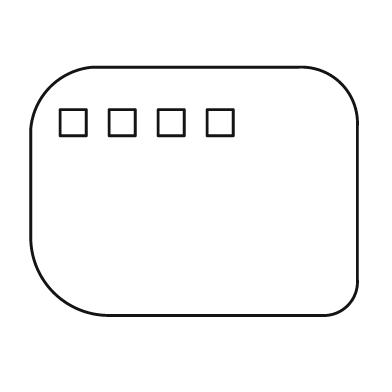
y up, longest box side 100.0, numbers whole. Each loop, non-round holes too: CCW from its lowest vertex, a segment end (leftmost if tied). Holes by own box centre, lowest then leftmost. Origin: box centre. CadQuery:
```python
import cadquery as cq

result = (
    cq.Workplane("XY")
    .moveTo(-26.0, -38.0)
    .lineTo(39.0, -38.0)
    .threePointArc((47.0, -35.0), (50.0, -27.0))
    .lineTo(50.0, 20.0)
    .threePointArc((45.0, 33.0), (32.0, 38.0))
    .lineTo(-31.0, 38.0)
    .threePointArc((-44.0, 32.0), (-50.0, 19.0))
    .lineTo(-50.0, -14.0)
    .threePointArc((-43.0, -31.0), (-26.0, -38.0))
    .close()
    .moveTo(-41.0, 17.0)
    .lineTo(-33.0, 17.0)
    .lineTo(-33.0, 25.0)
    .lineTo(-41.0, 25.0)
    .close()
    .moveTo(-26.0, 17.0)
    .lineTo(-18.0, 17.0)
    .lineTo(-18.0, 25.0)
    .lineTo(-26.0, 25.0)
    .close()
    .moveTo(-11.0, 17.0)
    .lineTo(-3.0, 17.0)
    .lineTo(-3.0, 25.0)
    .lineTo(-11.0, 25.0)
    .close()
    .moveTo(4.0, 17.0)
    .lineTo(12.0, 17.0)
    .lineTo(12.0, 25.0)
    .lineTo(4.0, 25.0)
    .close()
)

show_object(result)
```